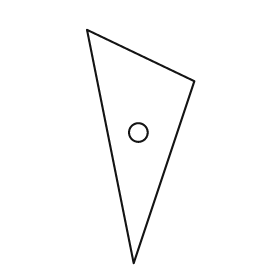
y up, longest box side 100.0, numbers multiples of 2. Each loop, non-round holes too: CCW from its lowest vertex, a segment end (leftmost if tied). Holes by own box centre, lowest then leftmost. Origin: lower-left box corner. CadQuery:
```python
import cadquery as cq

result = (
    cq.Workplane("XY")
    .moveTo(20.0, 0.0)
    .lineTo(46.0, 78.0)
    .lineTo(0.0, 100.0)
    .close()
    .moveTo(22.0, 56.0)
    .circle(4.0)
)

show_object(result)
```